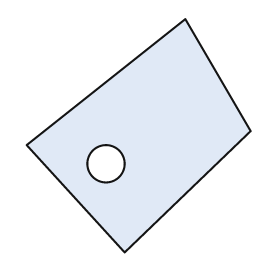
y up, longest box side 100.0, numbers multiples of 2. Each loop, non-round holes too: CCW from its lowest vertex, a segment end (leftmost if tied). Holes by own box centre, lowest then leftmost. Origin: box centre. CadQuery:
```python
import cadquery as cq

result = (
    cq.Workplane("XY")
    .moveTo(-6.0, -50.0)
    .lineTo(48.0, 2.0)
    .lineTo(20.0, 50.0)
    .lineTo(-48.0, -4.0)
    .close()
    .moveTo(-14.0, -12.0)
    .circle(8.0)
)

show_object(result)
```